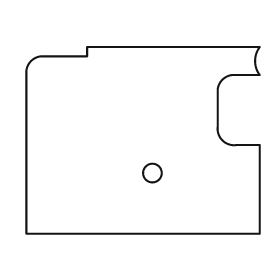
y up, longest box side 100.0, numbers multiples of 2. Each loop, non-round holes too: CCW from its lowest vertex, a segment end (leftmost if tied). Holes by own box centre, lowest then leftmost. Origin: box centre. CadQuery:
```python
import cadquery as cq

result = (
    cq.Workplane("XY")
    .moveTo(-50.0, -40.0)
    .lineTo(50.0, -40.0)
    .lineTo(50.0, -2.0)
    .lineTo(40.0, -2.0)
    .threePointArc((34.0, 0.0), (32.0, 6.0))
    .lineTo(32.0, 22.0)
    .threePointArc((34.0, 26.0), (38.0, 28.0))
    .lineTo(50.0, 28.0)
    .threePointArc((48.0, 34.0), (50.0, 40.0))
    .lineTo(-24.0, 40.0)
    .lineTo(-24.0, 36.0)
    .lineTo(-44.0, 36.0)
    .threePointArc((-48.0, 34.0), (-50.0, 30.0))
    .close()
    .moveTo(4.0, -14.0)
    .circle(4.0)
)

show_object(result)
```